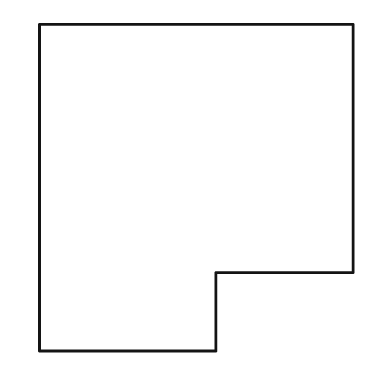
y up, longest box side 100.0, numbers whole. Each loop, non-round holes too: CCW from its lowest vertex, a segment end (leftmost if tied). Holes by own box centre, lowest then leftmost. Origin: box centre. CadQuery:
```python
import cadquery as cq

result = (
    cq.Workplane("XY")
    .moveTo(-48.0, -50.0)
    .lineTo(6.0, -50.0)
    .lineTo(6.0, -26.0)
    .lineTo(48.0, -26.0)
    .lineTo(48.0, 50.0)
    .lineTo(-48.0, 50.0)
    .close()
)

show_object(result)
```